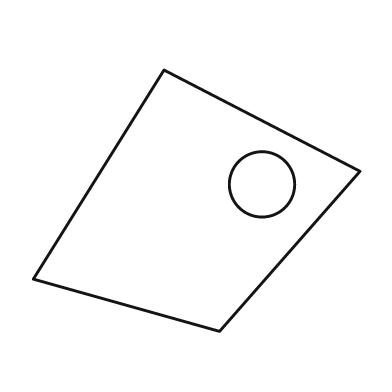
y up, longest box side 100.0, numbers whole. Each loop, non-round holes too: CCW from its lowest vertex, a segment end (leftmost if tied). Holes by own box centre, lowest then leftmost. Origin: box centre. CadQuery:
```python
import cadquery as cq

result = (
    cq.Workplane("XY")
    .moveTo(7.0, -40.0)
    .lineTo(50.0, 9.0)
    .lineTo(-10.0, 40.0)
    .lineTo(-50.0, -24.0)
    .close()
    .moveTo(20.0, 5.0)
    .circle(10.0)
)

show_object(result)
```